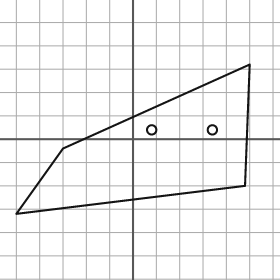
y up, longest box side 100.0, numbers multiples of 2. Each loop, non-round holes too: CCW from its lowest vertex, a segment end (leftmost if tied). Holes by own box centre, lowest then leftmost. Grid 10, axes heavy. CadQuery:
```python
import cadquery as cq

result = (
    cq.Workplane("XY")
    .moveTo(-50.0, -32.0)
    .lineTo(48.0, -20.0)
    .lineTo(50.0, 32.0)
    .lineTo(-30.0, -4.0)
    .close()
    .moveTo(8.0, 4.0)
    .circle(2.0)
    .moveTo(34.0, 4.0)
    .circle(2.0)
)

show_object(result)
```